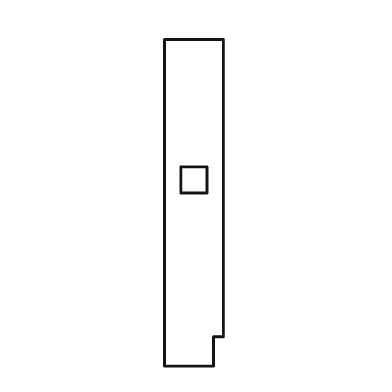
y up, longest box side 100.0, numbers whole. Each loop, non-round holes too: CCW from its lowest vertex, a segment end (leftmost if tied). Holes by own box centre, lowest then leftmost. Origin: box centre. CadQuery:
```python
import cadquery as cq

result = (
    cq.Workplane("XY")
    .moveTo(-9.0, -50.0)
    .lineTo(6.0, -50.0)
    .lineTo(6.0, -41.0)
    .lineTo(9.0, -41.0)
    .lineTo(9.0, 50.0)
    .lineTo(-9.0, 50.0)
    .close()
    .moveTo(-4.0, 3.0)
    .lineTo(4.0, 3.0)
    .lineTo(4.0, 11.0)
    .lineTo(-4.0, 11.0)
    .close()
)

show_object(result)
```